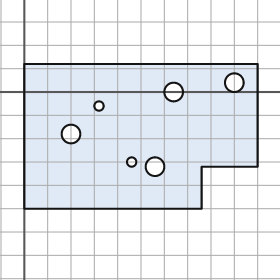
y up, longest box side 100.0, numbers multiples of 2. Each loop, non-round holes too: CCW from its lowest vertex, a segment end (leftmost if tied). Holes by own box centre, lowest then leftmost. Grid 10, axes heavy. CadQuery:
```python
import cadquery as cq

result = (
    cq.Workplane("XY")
    .moveTo(0.0, -50.0)
    .lineTo(76.0, -50.0)
    .lineTo(76.0, -32.0)
    .lineTo(100.0, -32.0)
    .lineTo(100.0, 12.0)
    .lineTo(0.0, 12.0)
    .close()
    .moveTo(56.0, -32.0)
    .circle(4.0)
    .moveTo(46.0, -30.0)
    .circle(2.0)
    .moveTo(20.0, -18.0)
    .circle(4.0)
    .moveTo(32.0, -6.0)
    .circle(2.0)
    .moveTo(64.0, 0.0)
    .circle(4.0)
    .moveTo(90.0, 4.0)
    .circle(4.0)
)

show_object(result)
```